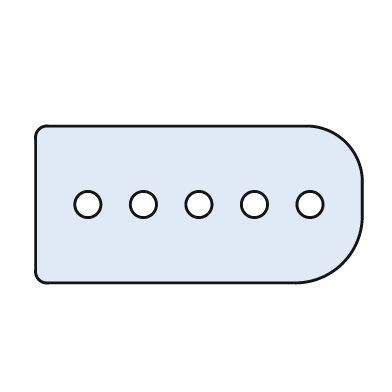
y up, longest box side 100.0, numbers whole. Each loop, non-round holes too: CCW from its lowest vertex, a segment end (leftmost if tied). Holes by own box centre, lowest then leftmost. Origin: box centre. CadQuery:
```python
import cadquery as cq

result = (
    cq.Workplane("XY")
    .moveTo(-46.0, -24.0)
    .lineTo(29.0, -24.0)
    .threePointArc((44.0, -18.0), (50.0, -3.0))
    .lineTo(50.0, 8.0)
    .threePointArc((45.0, 19.0), (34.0, 24.0))
    .lineTo(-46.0, 24.0)
    .threePointArc((-49.0, 23.0), (-50.0, 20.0))
    .lineTo(-50.0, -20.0)
    .threePointArc((-49.0, -23.0), (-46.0, -24.0))
    .close()
    .moveTo(-34.0, 0.0)
    .circle(4.0)
    .moveTo(-17.0, 0.0)
    .circle(4.0)
    .moveTo(0.0, 0.0)
    .circle(4.0)
    .moveTo(17.0, 0.0)
    .circle(4.0)
    .moveTo(34.0, 0.0)
    .circle(4.0)
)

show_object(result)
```